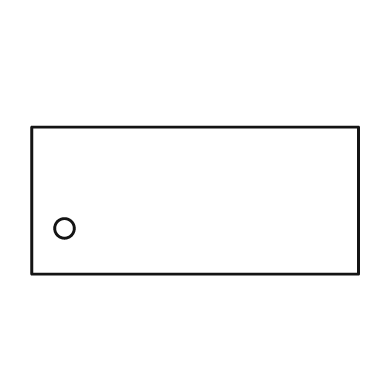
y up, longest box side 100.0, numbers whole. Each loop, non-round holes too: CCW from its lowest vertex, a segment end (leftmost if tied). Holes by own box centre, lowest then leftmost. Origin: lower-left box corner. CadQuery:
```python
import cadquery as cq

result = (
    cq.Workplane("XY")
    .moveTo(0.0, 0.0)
    .lineTo(100.0, 0.0)
    .lineTo(100.0, 45.0)
    .lineTo(0.0, 45.0)
    .close()
    .moveTo(10.0, 14.0)
    .circle(3.0)
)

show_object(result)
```